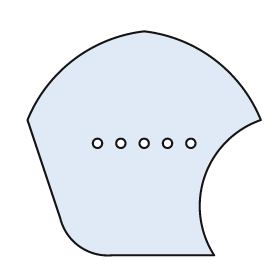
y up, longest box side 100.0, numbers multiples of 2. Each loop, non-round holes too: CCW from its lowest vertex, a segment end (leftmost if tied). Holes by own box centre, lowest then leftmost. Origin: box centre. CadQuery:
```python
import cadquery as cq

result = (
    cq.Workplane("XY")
    .moveTo(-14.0, -48.0)
    .lineTo(30.0, -48.0)
    .threePointArc((26.0, -14.0), (50.0, 10.0))
    .threePointArc((30.0, 36.0), (0.0, 48.0))
    .threePointArc((-30.0, 36.0), (-50.0, 10.0))
    .lineTo(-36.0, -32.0)
    .threePointArc((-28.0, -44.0), (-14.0, -48.0))
    .close()
    .moveTo(-20.0, 0.0)
    .circle(2.0)
    .moveTo(-10.0, 0.0)
    .circle(2.0)
    .moveTo(0.0, 0.0)
    .circle(2.0)
    .moveTo(10.0, 0.0)
    .circle(2.0)
    .moveTo(20.0, 0.0)
    .circle(2.0)
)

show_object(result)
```